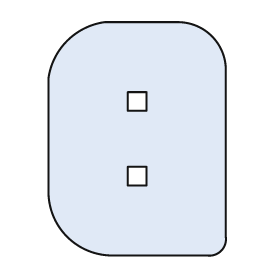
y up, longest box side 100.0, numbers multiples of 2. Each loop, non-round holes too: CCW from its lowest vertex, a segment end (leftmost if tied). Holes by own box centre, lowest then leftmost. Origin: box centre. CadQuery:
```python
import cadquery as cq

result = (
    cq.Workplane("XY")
    .moveTo(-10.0, -50.0)
    .lineTo(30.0, -50.0)
    .threePointArc((36.0, -48.0), (38.0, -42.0))
    .lineTo(38.0, 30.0)
    .threePointArc((32.0, 44.0), (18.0, 50.0))
    .lineTo(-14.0, 50.0)
    .threePointArc((-30.0, 42.0), (-38.0, 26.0))
    .lineTo(-38.0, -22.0)
    .threePointArc((-30.0, -42.0), (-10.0, -50.0))
    .close()
    .moveTo(-4.0, -20.0)
    .lineTo(4.0, -20.0)
    .lineTo(4.0, -12.0)
    .lineTo(-4.0, -12.0)
    .close()
    .moveTo(-4.0, 12.0)
    .lineTo(4.0, 12.0)
    .lineTo(4.0, 20.0)
    .lineTo(-4.0, 20.0)
    .close()
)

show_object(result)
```